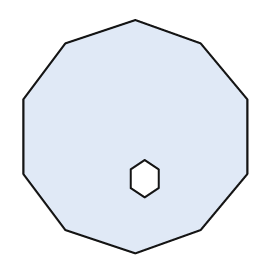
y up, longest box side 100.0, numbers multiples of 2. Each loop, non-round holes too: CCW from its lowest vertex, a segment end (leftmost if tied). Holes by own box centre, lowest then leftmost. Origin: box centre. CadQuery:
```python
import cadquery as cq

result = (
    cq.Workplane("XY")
    .moveTo(0.0, -50.0)
    .lineTo(28.0, -40.0)
    .lineTo(48.0, -16.0)
    .lineTo(48.0, 16.0)
    .lineTo(28.0, 40.0)
    .lineTo(0.0, 50.0)
    .lineTo(-30.0, 40.0)
    .lineTo(-48.0, 16.0)
    .lineTo(-48.0, -16.0)
    .lineTo(-30.0, -40.0)
    .close()
    .moveTo(4.0, -26.0)
    .lineTo(10.0, -22.0)
    .lineTo(10.0, -14.0)
    .lineTo(4.0, -10.0)
    .lineTo(-2.0, -14.0)
    .lineTo(-2.0, -22.0)
    .close()
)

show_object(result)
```